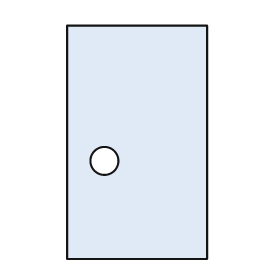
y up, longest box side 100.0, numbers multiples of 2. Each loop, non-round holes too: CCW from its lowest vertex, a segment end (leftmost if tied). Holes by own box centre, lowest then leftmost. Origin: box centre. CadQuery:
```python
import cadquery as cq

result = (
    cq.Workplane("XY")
    .moveTo(-30.0, -50.0)
    .lineTo(30.0, -50.0)
    .lineTo(30.0, 50.0)
    .lineTo(-30.0, 50.0)
    .close()
    .moveTo(-14.0, -8.0)
    .circle(6.0)
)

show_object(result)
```